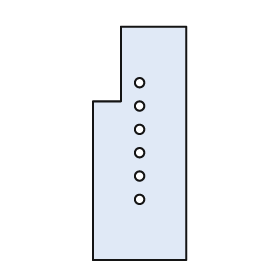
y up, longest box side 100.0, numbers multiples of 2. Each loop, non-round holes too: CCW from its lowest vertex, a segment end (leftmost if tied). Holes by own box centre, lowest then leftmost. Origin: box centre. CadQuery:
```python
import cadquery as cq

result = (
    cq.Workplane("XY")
    .moveTo(-20.0, -50.0)
    .lineTo(20.0, -50.0)
    .lineTo(20.0, 50.0)
    .lineTo(-8.0, 50.0)
    .lineTo(-8.0, 18.0)
    .lineTo(-20.0, 18.0)
    .close()
    .moveTo(0.0, -24.0)
    .circle(2.0)
    .moveTo(0.0, -14.0)
    .circle(2.0)
    .moveTo(0.0, -4.0)
    .circle(2.0)
    .moveTo(0.0, 6.0)
    .circle(2.0)
    .moveTo(0.0, 16.0)
    .circle(2.0)
    .moveTo(0.0, 26.0)
    .circle(2.0)
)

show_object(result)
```